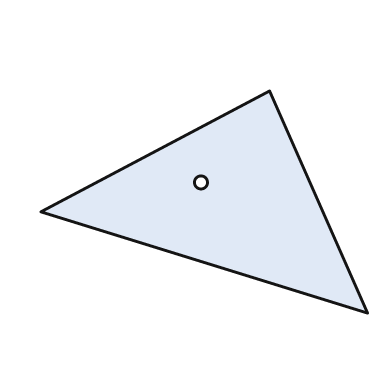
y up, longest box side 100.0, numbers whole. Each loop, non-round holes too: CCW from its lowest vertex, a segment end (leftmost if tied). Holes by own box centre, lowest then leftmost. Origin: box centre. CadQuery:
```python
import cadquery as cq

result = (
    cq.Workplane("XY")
    .moveTo(50.0, -34.0)
    .lineTo(20.0, 34.0)
    .lineTo(-50.0, -3.0)
    .close()
    .moveTo(-1.0, 6.0)
    .circle(2.0)
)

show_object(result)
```